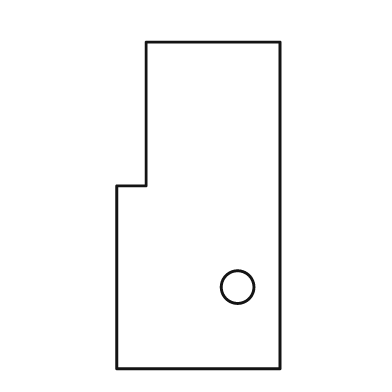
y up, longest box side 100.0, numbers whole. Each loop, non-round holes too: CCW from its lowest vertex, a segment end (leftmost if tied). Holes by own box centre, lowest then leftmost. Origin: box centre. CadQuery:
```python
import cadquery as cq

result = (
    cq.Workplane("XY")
    .moveTo(-25.0, -50.0)
    .lineTo(25.0, -50.0)
    .lineTo(25.0, 50.0)
    .lineTo(-16.0, 50.0)
    .lineTo(-16.0, 6.0)
    .lineTo(-25.0, 6.0)
    .close()
    .moveTo(12.0, -25.0)
    .circle(5.0)
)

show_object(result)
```